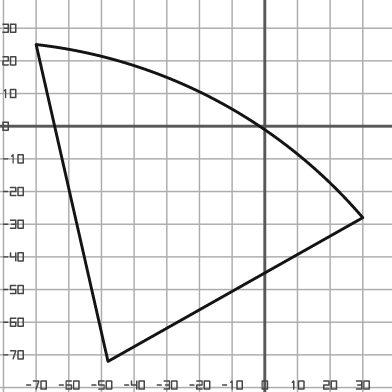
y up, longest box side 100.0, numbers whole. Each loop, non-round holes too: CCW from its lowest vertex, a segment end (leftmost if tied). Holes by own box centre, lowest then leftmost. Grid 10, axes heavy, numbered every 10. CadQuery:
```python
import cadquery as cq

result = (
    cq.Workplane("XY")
    .moveTo(-48.0, -72.0)
    .lineTo(30.0, -28.0)
    .threePointArc((-15.0, 8.0), (-70.0, 25.0))
    .close()
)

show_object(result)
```